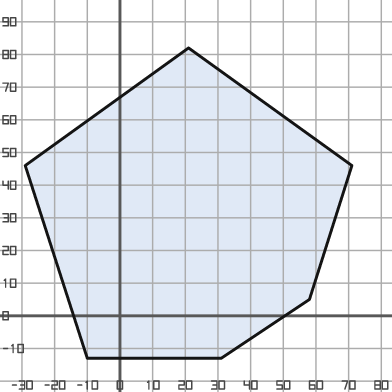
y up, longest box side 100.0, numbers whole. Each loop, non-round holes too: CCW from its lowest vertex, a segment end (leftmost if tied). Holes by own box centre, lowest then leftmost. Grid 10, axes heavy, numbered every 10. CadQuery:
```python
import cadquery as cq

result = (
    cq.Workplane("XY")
    .moveTo(-10.0, -13.0)
    .lineTo(31.0, -13.0)
    .lineTo(58.0, 5.0)
    .lineTo(71.0, 46.0)
    .lineTo(21.0, 82.0)
    .lineTo(-29.0, 46.0)
    .close()
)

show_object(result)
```